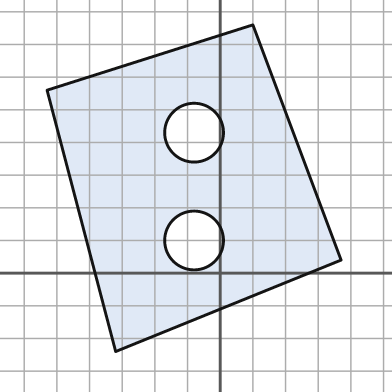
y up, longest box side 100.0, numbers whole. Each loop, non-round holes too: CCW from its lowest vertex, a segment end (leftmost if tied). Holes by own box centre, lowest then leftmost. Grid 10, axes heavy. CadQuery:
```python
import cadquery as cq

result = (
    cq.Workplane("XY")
    .moveTo(-32.0, -24.0)
    .lineTo(37.0, 4.0)
    .lineTo(10.0, 76.0)
    .lineTo(-53.0, 56.0)
    .close()
    .moveTo(-8.0, 10.0)
    .circle(9.0)
    .moveTo(-8.0, 43.0)
    .circle(9.0)
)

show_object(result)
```